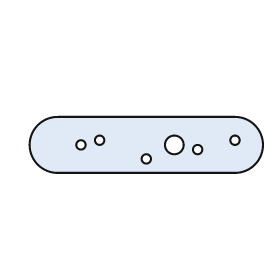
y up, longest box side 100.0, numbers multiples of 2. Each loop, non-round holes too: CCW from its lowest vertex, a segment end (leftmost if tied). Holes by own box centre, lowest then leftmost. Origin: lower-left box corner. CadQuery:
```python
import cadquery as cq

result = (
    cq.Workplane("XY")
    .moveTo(12.0, 0.0)
    .lineTo(88.0, 0.0)
    .threePointArc((100.0, 12.0), (88.0, 24.0))
    .lineTo(12.0, 24.0)
    .threePointArc((0.0, 12.0), (12.0, 0.0))
    .close()
    .moveTo(50.0, 6.0)
    .circle(2.0)
    .moveTo(72.0, 10.0)
    .circle(2.0)
    .moveTo(22.0, 12.0)
    .circle(2.0)
    .moveTo(62.0, 12.0)
    .circle(4.0)
    .moveTo(30.0, 14.0)
    .circle(2.0)
    .moveTo(88.0, 14.0)
    .circle(2.0)
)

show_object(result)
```